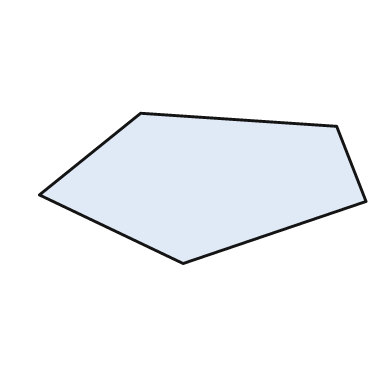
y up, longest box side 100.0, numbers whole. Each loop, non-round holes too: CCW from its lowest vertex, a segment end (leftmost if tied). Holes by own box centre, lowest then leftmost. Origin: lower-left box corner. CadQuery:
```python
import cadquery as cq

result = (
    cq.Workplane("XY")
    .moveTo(44.0, 0.0)
    .lineTo(100.0, 19.0)
    .lineTo(91.0, 42.0)
    .lineTo(31.0, 46.0)
    .lineTo(0.0, 21.0)
    .close()
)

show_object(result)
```